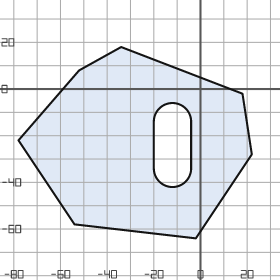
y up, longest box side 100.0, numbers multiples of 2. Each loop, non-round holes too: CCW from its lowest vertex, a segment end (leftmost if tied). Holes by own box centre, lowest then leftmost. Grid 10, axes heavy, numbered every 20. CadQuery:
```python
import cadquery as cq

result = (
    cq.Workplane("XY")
    .moveTo(-2.0, -64.0)
    .lineTo(22.0, -28.0)
    .lineTo(18.0, -2.0)
    .lineTo(-34.0, 18.0)
    .lineTo(-52.0, 8.0)
    .lineTo(-78.0, -22.0)
    .lineTo(-54.0, -58.0)
    .close()
    .moveTo(-20.0, -34.0)
    .threePointArc((-12.0, -42.0), (-4.0, -34.0))
    .lineTo(-4.0, -14.0)
    .threePointArc((-12.0, -6.0), (-20.0, -14.0))
    .close()
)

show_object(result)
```